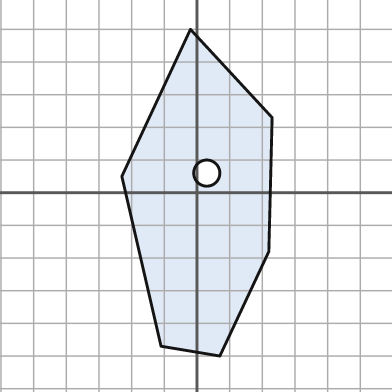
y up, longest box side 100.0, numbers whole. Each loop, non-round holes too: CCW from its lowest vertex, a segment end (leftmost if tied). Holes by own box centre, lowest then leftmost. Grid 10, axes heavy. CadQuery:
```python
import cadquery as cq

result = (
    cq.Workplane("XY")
    .moveTo(7.0, -50.0)
    .lineTo(22.0, -18.0)
    .lineTo(23.0, 23.0)
    .lineTo(-2.0, 50.0)
    .lineTo(-23.0, 5.0)
    .lineTo(-11.0, -47.0)
    .close()
    .moveTo(3.0, 6.0)
    .circle(4.0)
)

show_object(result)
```